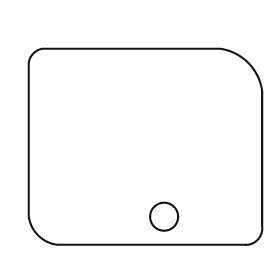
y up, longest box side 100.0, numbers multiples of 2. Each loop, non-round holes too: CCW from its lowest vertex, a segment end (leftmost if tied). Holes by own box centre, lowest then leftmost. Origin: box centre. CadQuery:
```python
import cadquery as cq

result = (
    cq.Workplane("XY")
    .moveTo(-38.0, -42.0)
    .lineTo(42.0, -42.0)
    .threePointArc((48.0, -40.0), (50.0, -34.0))
    .lineTo(50.0, 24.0)
    .threePointArc((44.0, 36.0), (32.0, 42.0))
    .lineTo(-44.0, 42.0)
    .threePointArc((-48.0, 40.0), (-50.0, 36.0))
    .lineTo(-50.0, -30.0)
    .threePointArc((-46.0, -38.0), (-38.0, -42.0))
    .close()
    .moveTo(8.0, -30.0)
    .circle(6.0)
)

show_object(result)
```